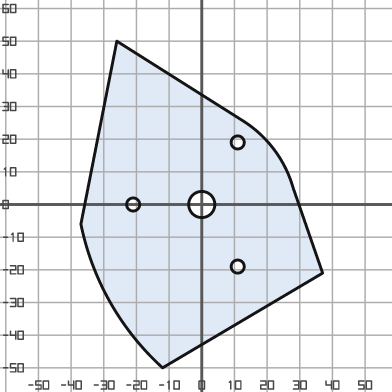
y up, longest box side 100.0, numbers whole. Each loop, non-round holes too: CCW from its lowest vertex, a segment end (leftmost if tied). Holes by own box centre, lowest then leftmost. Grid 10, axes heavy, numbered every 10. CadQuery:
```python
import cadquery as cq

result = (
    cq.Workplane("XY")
    .moveTo(-12.0, -50.0)
    .lineTo(37.0, -21.0)
    .lineTo(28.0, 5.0)
    .threePointArc((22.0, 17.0), (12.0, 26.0))
    .lineTo(-26.0, 50.0)
    .lineTo(-37.0, -6.0)
    .threePointArc((-28.0, -30.0), (-12.0, -50.0))
    .close()
    .moveTo(11.0, -19.0)
    .circle(2.0)
    .moveTo(-21.0, 0.0)
    .circle(2.0)
    .moveTo(0.0, 0.0)
    .circle(4.0)
    .moveTo(11.0, 19.0)
    .circle(2.0)
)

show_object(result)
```